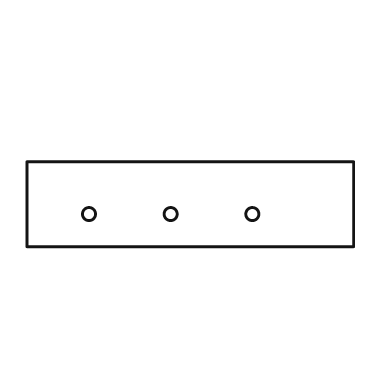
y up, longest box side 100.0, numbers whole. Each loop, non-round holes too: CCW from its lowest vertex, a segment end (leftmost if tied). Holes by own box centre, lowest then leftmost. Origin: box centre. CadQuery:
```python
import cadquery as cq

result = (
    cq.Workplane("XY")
    .moveTo(-50.0, -13.0)
    .lineTo(50.0, -13.0)
    .lineTo(50.0, 13.0)
    .lineTo(-50.0, 13.0)
    .close()
    .moveTo(-31.0, -3.0)
    .circle(2.0)
    .moveTo(-6.0, -3.0)
    .circle(2.0)
    .moveTo(19.0, -3.0)
    .circle(2.0)
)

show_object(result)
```